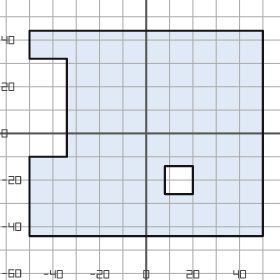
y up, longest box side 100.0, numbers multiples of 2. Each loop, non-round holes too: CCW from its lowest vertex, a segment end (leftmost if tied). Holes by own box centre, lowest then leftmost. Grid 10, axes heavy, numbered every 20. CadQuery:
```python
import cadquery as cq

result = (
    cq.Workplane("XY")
    .moveTo(-50.0, -44.0)
    .lineTo(50.0, -44.0)
    .lineTo(50.0, 44.0)
    .lineTo(-50.0, 44.0)
    .lineTo(-50.0, 32.0)
    .lineTo(-34.0, 32.0)
    .lineTo(-34.0, -10.0)
    .lineTo(-50.0, -10.0)
    .close()
    .moveTo(8.0, -26.0)
    .lineTo(20.0, -26.0)
    .lineTo(20.0, -14.0)
    .lineTo(8.0, -14.0)
    .close()
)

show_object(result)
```